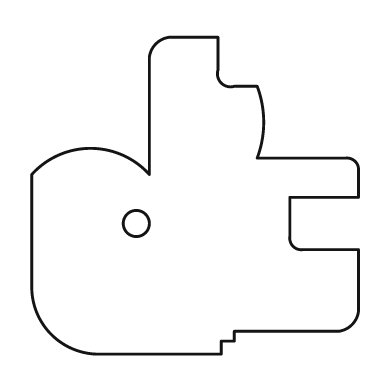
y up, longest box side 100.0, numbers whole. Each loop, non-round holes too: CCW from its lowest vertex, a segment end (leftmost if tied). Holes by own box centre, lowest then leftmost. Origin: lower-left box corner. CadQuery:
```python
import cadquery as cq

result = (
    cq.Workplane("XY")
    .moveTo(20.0, 0.0)
    .lineTo(58.0, 0.0)
    .lineTo(58.0, 4.0)
    .lineTo(62.0, 4.0)
    .lineTo(62.0, 7.0)
    .lineTo(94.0, 7.0)
    .threePointArc((98.0, 9.0), (100.0, 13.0))
    .lineTo(100.0, 32.0)
    .lineTo(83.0, 32.0)
    .threePointArc((80.0, 33.0), (79.0, 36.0))
    .lineTo(79.0, 48.0)
    .lineTo(100.0, 48.0)
    .lineTo(100.0, 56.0)
    .threePointArc((99.0, 59.0), (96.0, 60.0))
    .lineTo(69.0, 60.0)
    .threePointArc((71.0, 71.0), (69.0, 82.0))
    .lineTo(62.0, 82.0)
    .threePointArc((58.0, 83.0), (57.0, 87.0))
    .lineTo(57.0, 97.0)
    .lineTo(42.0, 97.0)
    .threePointArc((38.0, 95.0), (36.0, 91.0))
    .lineTo(36.0, 55.0)
    .threePointArc((18.0, 63.0), (0.0, 55.0))
    .lineTo(0.0, 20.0)
    .threePointArc((6.0, 6.0), (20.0, 0.0))
    .close()
    .moveTo(32.0, 40.0)
    .circle(4.0)
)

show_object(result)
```